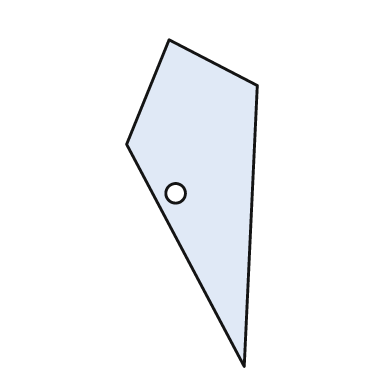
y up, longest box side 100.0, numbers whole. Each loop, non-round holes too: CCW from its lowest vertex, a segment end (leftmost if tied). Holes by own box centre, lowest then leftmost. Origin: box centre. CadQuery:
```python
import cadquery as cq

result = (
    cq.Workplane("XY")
    .moveTo(16.0, -50.0)
    .lineTo(20.0, 36.0)
    .lineTo(-7.0, 50.0)
    .lineTo(-20.0, 18.0)
    .close()
    .moveTo(-5.0, 3.0)
    .circle(3.0)
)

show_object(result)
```